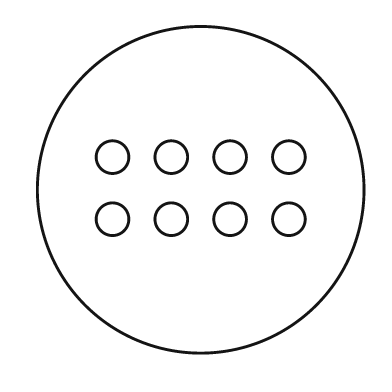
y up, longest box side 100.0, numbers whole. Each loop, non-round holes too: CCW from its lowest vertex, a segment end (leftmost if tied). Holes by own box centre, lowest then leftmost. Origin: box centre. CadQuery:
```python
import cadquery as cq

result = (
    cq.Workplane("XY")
    .moveTo(0.0, 0.0)
    .circle(50.0)
    .moveTo(-27.0, -9.0)
    .circle(5.0)
    .moveTo(-9.0, -9.0)
    .circle(5.0)
    .moveTo(9.0, -9.0)
    .circle(5.0)
    .moveTo(27.0, -9.0)
    .circle(5.0)
    .moveTo(-27.0, 10.0)
    .circle(5.0)
    .moveTo(-9.0, 10.0)
    .circle(5.0)
    .moveTo(9.0, 10.0)
    .circle(5.0)
    .moveTo(27.0, 10.0)
    .circle(5.0)
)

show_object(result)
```